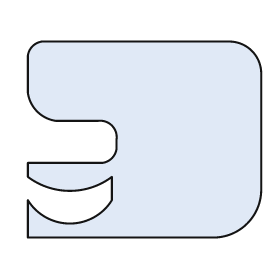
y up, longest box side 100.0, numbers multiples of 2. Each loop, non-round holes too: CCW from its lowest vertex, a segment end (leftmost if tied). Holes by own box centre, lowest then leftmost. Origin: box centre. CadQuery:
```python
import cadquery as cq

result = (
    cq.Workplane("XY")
    .moveTo(-50.0, -42.0)
    .lineTo(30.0, -42.0)
    .threePointArc((44.0, -36.0), (50.0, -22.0))
    .lineTo(50.0, 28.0)
    .threePointArc((46.0, 38.0), (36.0, 42.0))
    .lineTo(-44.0, 42.0)
    .threePointArc((-48.0, 40.0), (-50.0, 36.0))
    .lineTo(-50.0, 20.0)
    .threePointArc((-46.0, 12.0), (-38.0, 8.0))
    .lineTo(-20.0, 8.0)
    .threePointArc((-14.0, 6.0), (-12.0, 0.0))
    .lineTo(-12.0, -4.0)
    .threePointArc((-14.0, -8.0), (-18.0, -10.0))
    .lineTo(-50.0, -10.0)
    .lineTo(-50.0, -16.0)
    .threePointArc((-32.0, -22.0), (-14.0, -16.0))
    .lineTo(-14.0, -26.0)
    .threePointArc((-32.0, -36.0), (-50.0, -26.0))
    .close()
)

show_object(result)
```